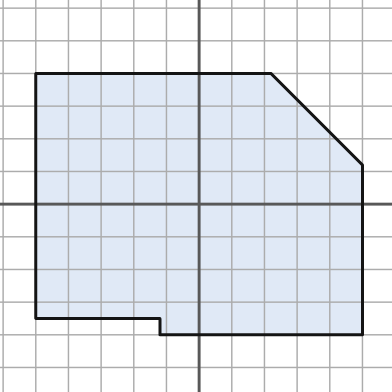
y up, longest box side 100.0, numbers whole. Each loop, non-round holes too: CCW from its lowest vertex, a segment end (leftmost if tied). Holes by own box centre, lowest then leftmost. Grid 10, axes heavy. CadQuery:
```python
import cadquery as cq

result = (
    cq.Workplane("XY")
    .moveTo(-12.0, -40.0)
    .lineTo(50.0, -40.0)
    .lineTo(50.0, 12.0)
    .lineTo(22.0, 40.0)
    .lineTo(-50.0, 40.0)
    .lineTo(-50.0, -35.0)
    .lineTo(-12.0, -35.0)
    .close()
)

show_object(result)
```